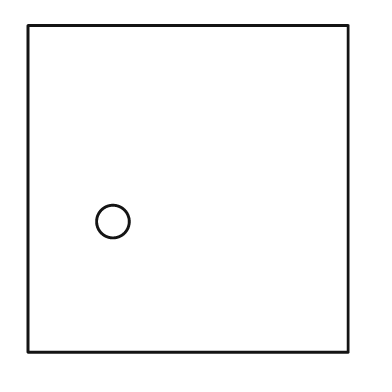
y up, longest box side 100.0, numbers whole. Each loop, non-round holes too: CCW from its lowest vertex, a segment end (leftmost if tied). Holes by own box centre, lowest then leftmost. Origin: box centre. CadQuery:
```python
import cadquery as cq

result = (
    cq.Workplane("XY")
    .moveTo(-49.0, -50.0)
    .lineTo(49.0, -50.0)
    .lineTo(49.0, 50.0)
    .lineTo(-49.0, 50.0)
    .close()
    .moveTo(-23.0, -10.0)
    .circle(5.0)
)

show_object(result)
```